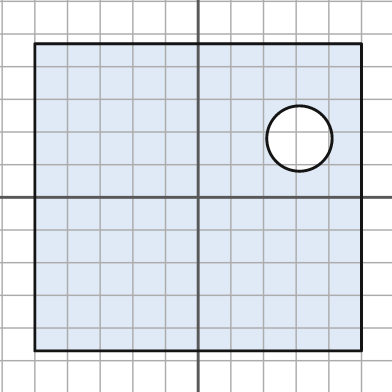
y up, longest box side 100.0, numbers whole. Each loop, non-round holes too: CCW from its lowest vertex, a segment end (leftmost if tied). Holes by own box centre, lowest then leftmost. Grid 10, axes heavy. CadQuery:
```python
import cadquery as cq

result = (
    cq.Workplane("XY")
    .moveTo(-50.0, -47.0)
    .lineTo(50.0, -47.0)
    .lineTo(50.0, 47.0)
    .lineTo(-50.0, 47.0)
    .close()
    .moveTo(31.0, 18.0)
    .circle(10.0)
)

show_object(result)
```